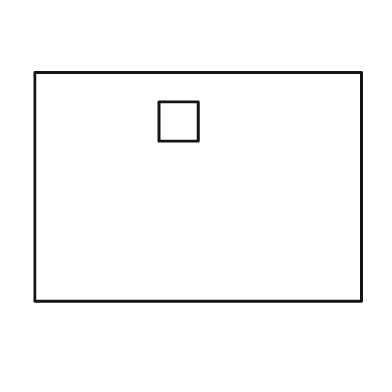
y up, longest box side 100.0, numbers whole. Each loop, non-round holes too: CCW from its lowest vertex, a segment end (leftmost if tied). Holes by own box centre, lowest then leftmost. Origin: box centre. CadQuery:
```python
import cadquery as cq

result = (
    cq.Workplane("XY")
    .moveTo(-50.0, -35.0)
    .lineTo(50.0, -35.0)
    .lineTo(50.0, 35.0)
    .lineTo(-50.0, 35.0)
    .close()
    .moveTo(-12.0, 14.0)
    .lineTo(0.0, 14.0)
    .lineTo(0.0, 26.0)
    .lineTo(-12.0, 26.0)
    .close()
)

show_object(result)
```